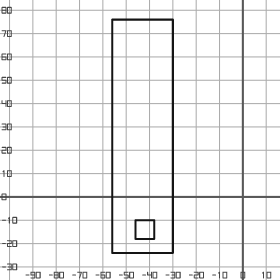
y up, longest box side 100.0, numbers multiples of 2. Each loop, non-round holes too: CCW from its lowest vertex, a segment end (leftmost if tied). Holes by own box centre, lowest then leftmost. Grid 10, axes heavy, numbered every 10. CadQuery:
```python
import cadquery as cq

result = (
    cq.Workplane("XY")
    .moveTo(-56.0, -24.0)
    .lineTo(-30.0, -24.0)
    .lineTo(-30.0, 76.0)
    .lineTo(-56.0, 76.0)
    .close()
    .moveTo(-46.0, -18.0)
    .lineTo(-38.0, -18.0)
    .lineTo(-38.0, -10.0)
    .lineTo(-46.0, -10.0)
    .close()
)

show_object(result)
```